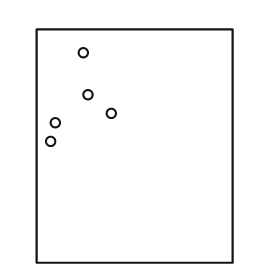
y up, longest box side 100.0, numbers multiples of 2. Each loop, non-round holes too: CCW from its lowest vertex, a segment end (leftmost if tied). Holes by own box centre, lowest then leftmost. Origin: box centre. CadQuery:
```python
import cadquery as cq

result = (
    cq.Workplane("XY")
    .moveTo(-42.0, -50.0)
    .lineTo(42.0, -50.0)
    .lineTo(42.0, 50.0)
    .lineTo(-42.0, 50.0)
    .close()
    .moveTo(-36.0, 2.0)
    .circle(2.0)
    .moveTo(-34.0, 10.0)
    .circle(2.0)
    .moveTo(-10.0, 14.0)
    .circle(2.0)
    .moveTo(-20.0, 22.0)
    .circle(2.0)
    .moveTo(-22.0, 40.0)
    .circle(2.0)
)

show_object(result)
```